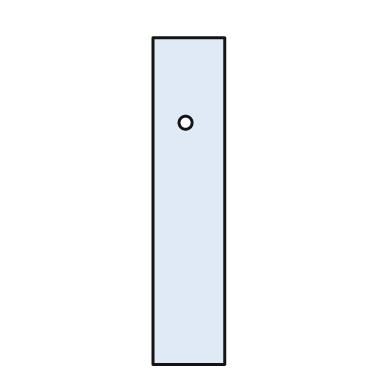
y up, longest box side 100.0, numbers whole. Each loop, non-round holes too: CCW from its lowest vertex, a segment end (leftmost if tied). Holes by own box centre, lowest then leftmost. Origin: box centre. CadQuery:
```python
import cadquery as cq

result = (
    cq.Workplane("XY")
    .moveTo(-11.0, -50.0)
    .lineTo(11.0, -50.0)
    .lineTo(11.0, 50.0)
    .lineTo(-11.0, 50.0)
    .close()
    .moveTo(-1.0, 24.0)
    .circle(2.0)
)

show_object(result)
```